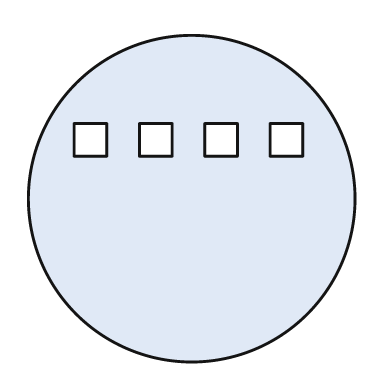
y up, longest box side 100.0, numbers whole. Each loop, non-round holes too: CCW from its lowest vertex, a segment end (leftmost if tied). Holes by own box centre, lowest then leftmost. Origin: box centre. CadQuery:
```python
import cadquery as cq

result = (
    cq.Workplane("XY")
    .moveTo(0.0, 0.0)
    .circle(50.0)
    .moveTo(-36.0, 13.0)
    .lineTo(-26.0, 13.0)
    .lineTo(-26.0, 23.0)
    .lineTo(-36.0, 23.0)
    .close()
    .moveTo(-16.0, 13.0)
    .lineTo(-6.0, 13.0)
    .lineTo(-6.0, 23.0)
    .lineTo(-16.0, 23.0)
    .close()
    .moveTo(4.0, 13.0)
    .lineTo(14.0, 13.0)
    .lineTo(14.0, 23.0)
    .lineTo(4.0, 23.0)
    .close()
    .moveTo(24.0, 13.0)
    .lineTo(34.0, 13.0)
    .lineTo(34.0, 23.0)
    .lineTo(24.0, 23.0)
    .close()
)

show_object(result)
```